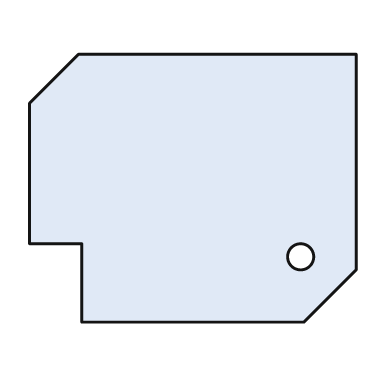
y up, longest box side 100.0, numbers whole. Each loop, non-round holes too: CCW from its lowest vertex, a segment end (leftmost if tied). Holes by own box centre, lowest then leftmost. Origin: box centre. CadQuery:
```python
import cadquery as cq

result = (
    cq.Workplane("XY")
    .moveTo(-34.0, -41.0)
    .lineTo(34.0, -41.0)
    .lineTo(50.0, -25.0)
    .lineTo(50.0, 41.0)
    .lineTo(-35.0, 41.0)
    .lineTo(-50.0, 26.0)
    .lineTo(-50.0, -17.0)
    .lineTo(-34.0, -17.0)
    .close()
    .moveTo(33.0, -21.0)
    .circle(4.0)
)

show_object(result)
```